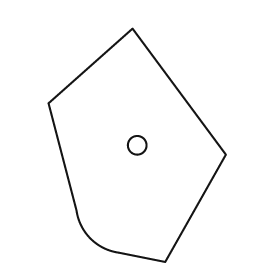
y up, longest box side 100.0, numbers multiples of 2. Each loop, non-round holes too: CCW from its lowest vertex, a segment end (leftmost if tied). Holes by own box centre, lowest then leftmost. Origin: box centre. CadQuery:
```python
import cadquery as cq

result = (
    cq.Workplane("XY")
    .moveTo(12.0, -50.0)
    .lineTo(38.0, -4.0)
    .lineTo(-2.0, 50.0)
    .lineTo(-38.0, 18.0)
    .lineTo(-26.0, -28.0)
    .threePointArc((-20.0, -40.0), (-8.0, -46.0))
    .close()
    .moveTo(0.0, 0.0)
    .circle(4.0)
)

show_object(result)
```